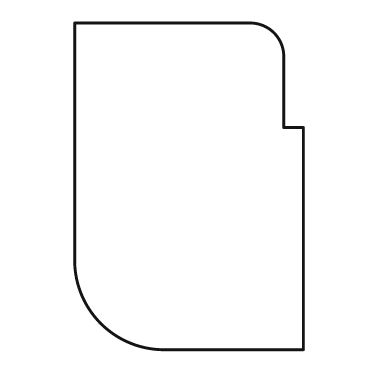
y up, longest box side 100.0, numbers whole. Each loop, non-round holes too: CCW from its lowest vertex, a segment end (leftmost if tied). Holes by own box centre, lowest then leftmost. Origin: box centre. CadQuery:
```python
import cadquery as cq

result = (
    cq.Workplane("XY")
    .moveTo(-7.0, -50.0)
    .lineTo(35.0, -50.0)
    .lineTo(35.0, 18.0)
    .lineTo(29.0, 18.0)
    .lineTo(29.0, 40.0)
    .threePointArc((26.0, 47.0), (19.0, 50.0))
    .lineTo(-35.0, 50.0)
    .lineTo(-35.0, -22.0)
    .threePointArc((-27.0, -42.0), (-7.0, -50.0))
    .close()
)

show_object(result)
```